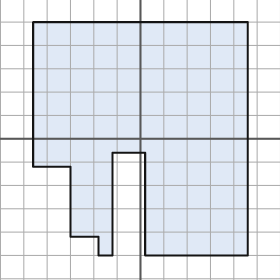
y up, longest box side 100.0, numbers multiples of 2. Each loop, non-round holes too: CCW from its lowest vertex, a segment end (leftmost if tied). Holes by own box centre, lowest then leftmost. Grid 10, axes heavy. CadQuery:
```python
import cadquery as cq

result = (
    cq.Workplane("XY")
    .moveTo(-18.0, -50.0)
    .lineTo(-12.0, -50.0)
    .lineTo(-12.0, -6.0)
    .lineTo(2.0, -6.0)
    .lineTo(2.0, -50.0)
    .lineTo(46.0, -50.0)
    .lineTo(46.0, 50.0)
    .lineTo(-46.0, 50.0)
    .lineTo(-46.0, -12.0)
    .lineTo(-30.0, -12.0)
    .lineTo(-30.0, -42.0)
    .lineTo(-18.0, -42.0)
    .close()
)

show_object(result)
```